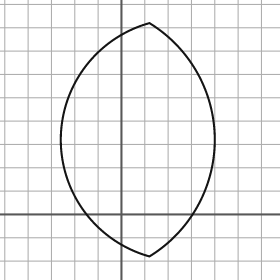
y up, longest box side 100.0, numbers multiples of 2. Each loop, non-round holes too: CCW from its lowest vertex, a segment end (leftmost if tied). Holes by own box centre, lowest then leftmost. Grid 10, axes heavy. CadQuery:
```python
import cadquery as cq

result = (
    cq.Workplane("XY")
    .moveTo(12.0, -18.0)
    .threePointArc((40.0, 32.0), (12.0, 82.0))
    .threePointArc((-26.0, 32.0), (12.0, -18.0))
    .close()
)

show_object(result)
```